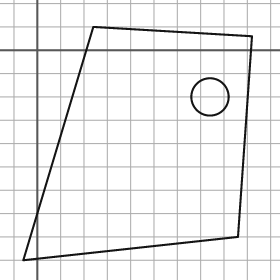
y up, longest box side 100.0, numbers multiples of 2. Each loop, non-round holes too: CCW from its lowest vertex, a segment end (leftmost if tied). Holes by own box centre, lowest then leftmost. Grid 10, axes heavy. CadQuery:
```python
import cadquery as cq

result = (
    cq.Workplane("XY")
    .moveTo(-6.0, -90.0)
    .lineTo(86.0, -80.0)
    .lineTo(92.0, 6.0)
    .lineTo(24.0, 10.0)
    .close()
    .moveTo(74.0, -20.0)
    .circle(8.0)
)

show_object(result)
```